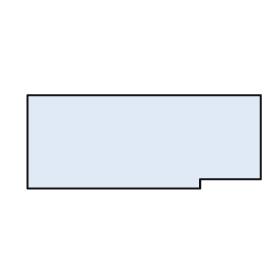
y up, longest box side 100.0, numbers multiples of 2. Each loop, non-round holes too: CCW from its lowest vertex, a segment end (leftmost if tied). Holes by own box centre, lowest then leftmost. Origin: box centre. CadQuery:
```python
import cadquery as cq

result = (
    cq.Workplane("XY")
    .moveTo(-50.0, -20.0)
    .lineTo(24.0, -20.0)
    .lineTo(24.0, -16.0)
    .lineTo(50.0, -16.0)
    .lineTo(50.0, 20.0)
    .lineTo(-50.0, 20.0)
    .close()
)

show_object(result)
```